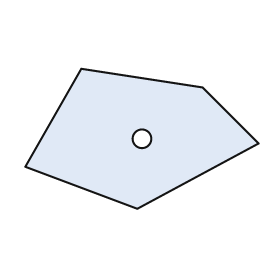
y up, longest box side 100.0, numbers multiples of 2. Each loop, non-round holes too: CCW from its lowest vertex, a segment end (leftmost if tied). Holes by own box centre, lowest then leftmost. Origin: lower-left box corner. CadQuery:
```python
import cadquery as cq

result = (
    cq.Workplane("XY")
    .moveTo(48.0, 0.0)
    .lineTo(100.0, 28.0)
    .lineTo(76.0, 52.0)
    .lineTo(24.0, 60.0)
    .lineTo(0.0, 18.0)
    .close()
    .moveTo(50.0, 30.0)
    .circle(4.0)
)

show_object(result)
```